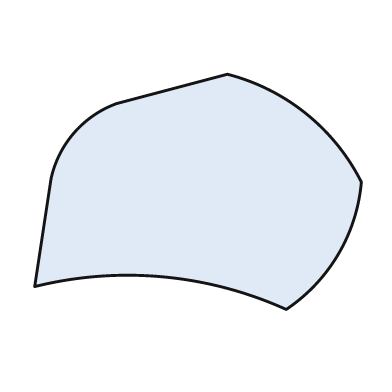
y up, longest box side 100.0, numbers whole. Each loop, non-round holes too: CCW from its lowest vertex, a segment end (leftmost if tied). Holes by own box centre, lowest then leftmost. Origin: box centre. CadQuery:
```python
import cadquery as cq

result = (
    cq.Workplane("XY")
    .moveTo(27.0, -36.0)
    .threePointArc((43.0, -19.0), (50.0, 3.0))
    .threePointArc((33.0, 24.0), (9.0, 36.0))
    .lineTo(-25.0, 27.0)
    .threePointArc((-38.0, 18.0), (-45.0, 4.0))
    .lineTo(-50.0, -29.0)
    .threePointArc((-11.0, -26.0), (27.0, -36.0))
    .close()
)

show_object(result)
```